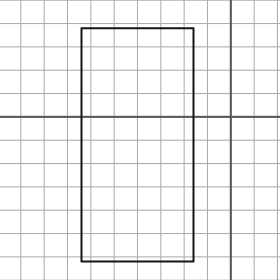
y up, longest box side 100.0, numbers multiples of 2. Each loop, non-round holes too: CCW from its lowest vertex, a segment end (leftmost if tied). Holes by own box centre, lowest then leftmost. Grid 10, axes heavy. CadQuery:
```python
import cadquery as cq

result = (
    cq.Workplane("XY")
    .moveTo(-64.0, -62.0)
    .lineTo(-16.0, -62.0)
    .lineTo(-16.0, 38.0)
    .lineTo(-64.0, 38.0)
    .close()
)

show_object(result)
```